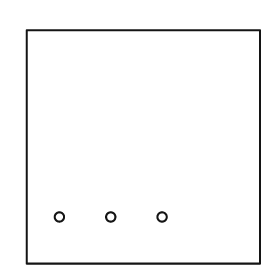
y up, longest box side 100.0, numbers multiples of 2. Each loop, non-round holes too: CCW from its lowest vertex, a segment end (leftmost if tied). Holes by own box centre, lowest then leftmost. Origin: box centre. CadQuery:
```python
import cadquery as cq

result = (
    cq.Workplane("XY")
    .moveTo(-50.0, -50.0)
    .lineTo(50.0, -50.0)
    .lineTo(50.0, 50.0)
    .lineTo(-50.0, 50.0)
    .close()
    .moveTo(-36.0, -30.0)
    .circle(2.0)
    .moveTo(-14.0, -30.0)
    .circle(2.0)
    .moveTo(8.0, -30.0)
    .circle(2.0)
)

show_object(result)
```